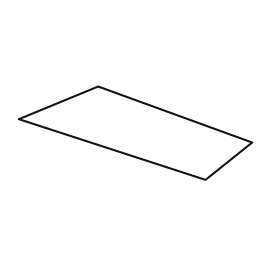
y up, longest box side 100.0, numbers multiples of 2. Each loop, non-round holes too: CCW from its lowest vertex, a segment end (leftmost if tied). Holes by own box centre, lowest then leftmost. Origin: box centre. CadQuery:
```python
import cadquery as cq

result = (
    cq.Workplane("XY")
    .moveTo(30.0, -20.0)
    .lineTo(50.0, -4.0)
    .lineTo(-16.0, 20.0)
    .lineTo(-50.0, 6.0)
    .close()
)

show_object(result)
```